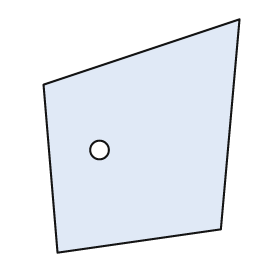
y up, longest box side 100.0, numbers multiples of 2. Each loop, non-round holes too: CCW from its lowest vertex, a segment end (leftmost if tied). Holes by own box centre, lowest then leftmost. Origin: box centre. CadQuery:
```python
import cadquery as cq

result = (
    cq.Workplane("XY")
    .moveTo(-36.0, -50.0)
    .lineTo(34.0, -40.0)
    .lineTo(42.0, 50.0)
    .lineTo(-42.0, 22.0)
    .close()
    .moveTo(-18.0, -6.0)
    .circle(4.0)
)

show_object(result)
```